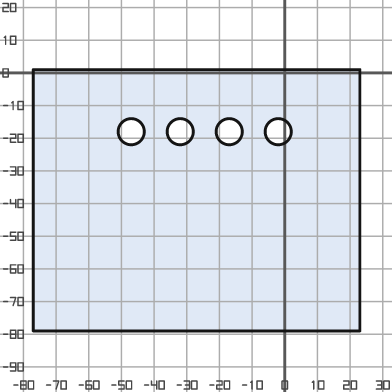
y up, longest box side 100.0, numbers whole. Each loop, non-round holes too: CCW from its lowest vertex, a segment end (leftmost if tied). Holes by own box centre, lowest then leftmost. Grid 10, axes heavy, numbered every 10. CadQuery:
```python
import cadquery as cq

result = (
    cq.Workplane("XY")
    .moveTo(-77.0, -79.0)
    .lineTo(23.0, -79.0)
    .lineTo(23.0, 1.0)
    .lineTo(-77.0, 1.0)
    .close()
    .moveTo(-47.0, -18.0)
    .circle(4.0)
    .moveTo(-32.0, -18.0)
    .circle(4.0)
    .moveTo(-17.0, -18.0)
    .circle(4.0)
    .moveTo(-2.0, -18.0)
    .circle(4.0)
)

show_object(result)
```